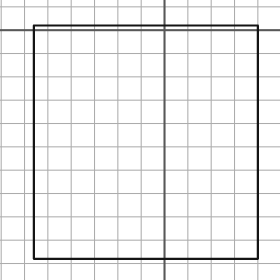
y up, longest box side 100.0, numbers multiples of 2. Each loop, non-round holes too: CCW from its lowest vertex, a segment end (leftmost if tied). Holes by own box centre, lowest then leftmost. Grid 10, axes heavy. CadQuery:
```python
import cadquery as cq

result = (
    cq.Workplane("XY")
    .moveTo(-56.0, -98.0)
    .lineTo(40.0, -98.0)
    .lineTo(40.0, 2.0)
    .lineTo(-56.0, 2.0)
    .close()
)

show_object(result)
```